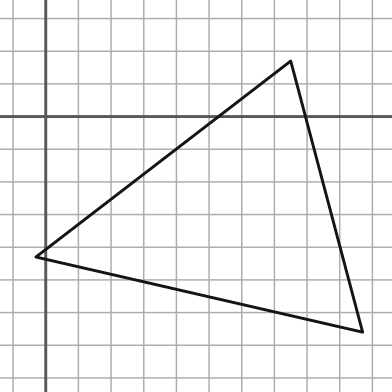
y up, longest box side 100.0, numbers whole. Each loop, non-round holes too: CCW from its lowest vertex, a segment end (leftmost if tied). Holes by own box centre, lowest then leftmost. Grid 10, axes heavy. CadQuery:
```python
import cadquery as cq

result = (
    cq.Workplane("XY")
    .moveTo(97.0, -66.0)
    .lineTo(75.0, 17.0)
    .lineTo(-3.0, -43.0)
    .close()
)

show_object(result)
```